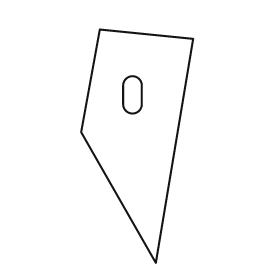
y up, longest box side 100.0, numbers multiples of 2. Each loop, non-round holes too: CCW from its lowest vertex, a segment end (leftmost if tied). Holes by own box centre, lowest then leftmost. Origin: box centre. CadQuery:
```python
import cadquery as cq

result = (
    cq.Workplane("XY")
    .moveTo(8.0, -50.0)
    .lineTo(24.0, 46.0)
    .lineTo(-16.0, 50.0)
    .lineTo(-24.0, 6.0)
    .close()
    .moveTo(-6.0, 18.0)
    .threePointArc((-2.0, 14.0), (2.0, 18.0))
    .lineTo(2.0, 26.0)
    .threePointArc((-2.0, 30.0), (-6.0, 26.0))
    .close()
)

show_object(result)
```